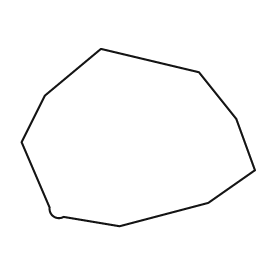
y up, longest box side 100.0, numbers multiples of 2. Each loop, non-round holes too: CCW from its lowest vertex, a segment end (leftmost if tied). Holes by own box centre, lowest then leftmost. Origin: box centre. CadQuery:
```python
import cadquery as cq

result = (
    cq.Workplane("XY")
    .moveTo(-8.0, -38.0)
    .lineTo(30.0, -28.0)
    .lineTo(50.0, -14.0)
    .lineTo(42.0, 8.0)
    .lineTo(26.0, 28.0)
    .lineTo(-16.0, 38.0)
    .lineTo(-40.0, 18.0)
    .lineTo(-50.0, -2.0)
    .lineTo(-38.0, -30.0)
    .threePointArc((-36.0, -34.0), (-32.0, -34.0))
    .close()
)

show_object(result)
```